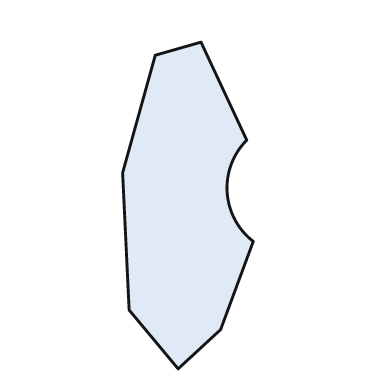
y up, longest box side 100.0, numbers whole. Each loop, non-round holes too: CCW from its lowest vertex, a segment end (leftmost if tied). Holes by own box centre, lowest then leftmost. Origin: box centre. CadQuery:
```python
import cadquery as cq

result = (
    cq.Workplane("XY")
    .moveTo(-3.0, -50.0)
    .lineTo(10.0, -38.0)
    .lineTo(20.0, -11.0)
    .threePointArc((12.0, 4.0), (18.0, 20.0))
    .lineTo(4.0, 50.0)
    .lineTo(-10.0, 46.0)
    .lineTo(-20.0, 10.0)
    .lineTo(-18.0, -32.0)
    .close()
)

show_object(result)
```